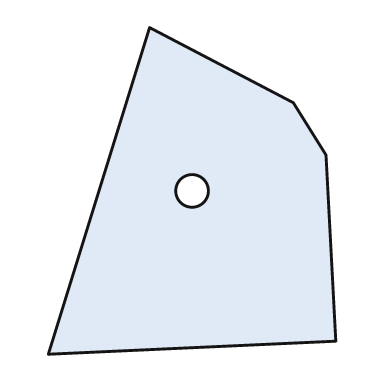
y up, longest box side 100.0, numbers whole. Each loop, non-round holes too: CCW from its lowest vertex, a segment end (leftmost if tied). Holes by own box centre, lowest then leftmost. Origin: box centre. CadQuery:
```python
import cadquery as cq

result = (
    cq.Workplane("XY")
    .moveTo(-44.0, -50.0)
    .lineTo(44.0, -46.0)
    .lineTo(41.0, 11.0)
    .lineTo(31.0, 27.0)
    .lineTo(-13.0, 50.0)
    .close()
    .moveTo(0.0, 0.0)
    .circle(5.0)
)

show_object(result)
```